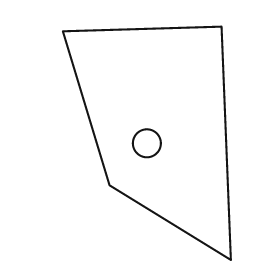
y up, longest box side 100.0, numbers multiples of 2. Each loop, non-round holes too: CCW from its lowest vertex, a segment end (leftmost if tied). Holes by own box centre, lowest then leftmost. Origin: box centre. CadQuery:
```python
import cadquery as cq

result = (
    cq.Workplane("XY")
    .moveTo(36.0, -50.0)
    .lineTo(32.0, 50.0)
    .lineTo(-36.0, 48.0)
    .lineTo(-16.0, -18.0)
    .close()
    .moveTo(0.0, 0.0)
    .circle(6.0)
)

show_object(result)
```